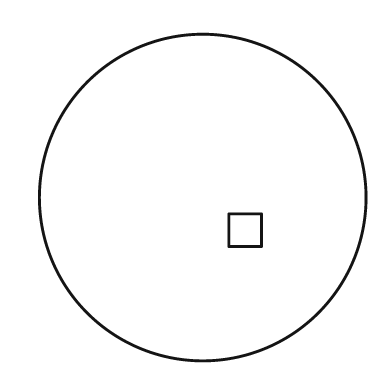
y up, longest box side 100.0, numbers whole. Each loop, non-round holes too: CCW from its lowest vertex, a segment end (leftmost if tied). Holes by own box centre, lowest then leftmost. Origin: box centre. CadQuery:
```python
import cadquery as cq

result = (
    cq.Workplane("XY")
    .moveTo(0.0, 0.0)
    .circle(50.0)
    .moveTo(8.0, -15.0)
    .lineTo(18.0, -15.0)
    .lineTo(18.0, -5.0)
    .lineTo(8.0, -5.0)
    .close()
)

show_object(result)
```